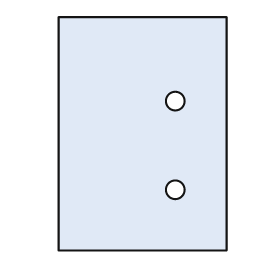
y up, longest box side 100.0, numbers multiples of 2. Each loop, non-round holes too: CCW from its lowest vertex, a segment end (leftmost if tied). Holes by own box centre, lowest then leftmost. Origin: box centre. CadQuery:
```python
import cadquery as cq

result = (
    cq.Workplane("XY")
    .moveTo(-36.0, -50.0)
    .lineTo(36.0, -50.0)
    .lineTo(36.0, 50.0)
    .lineTo(-36.0, 50.0)
    .close()
    .moveTo(14.0, -24.0)
    .circle(4.0)
    .moveTo(14.0, 14.0)
    .circle(4.0)
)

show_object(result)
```